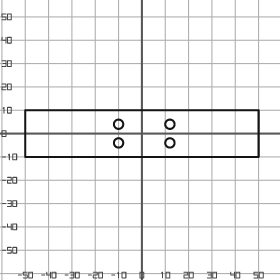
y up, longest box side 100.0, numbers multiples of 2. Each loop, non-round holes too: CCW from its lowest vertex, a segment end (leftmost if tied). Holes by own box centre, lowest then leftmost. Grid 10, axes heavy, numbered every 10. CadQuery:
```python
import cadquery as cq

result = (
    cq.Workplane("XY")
    .moveTo(-50.0, -10.0)
    .lineTo(50.0, -10.0)
    .lineTo(50.0, 10.0)
    .lineTo(-50.0, 10.0)
    .close()
    .moveTo(-10.0, -4.0)
    .circle(2.0)
    .moveTo(12.0, -4.0)
    .circle(2.0)
    .moveTo(-10.0, 4.0)
    .circle(2.0)
    .moveTo(12.0, 4.0)
    .circle(2.0)
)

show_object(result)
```